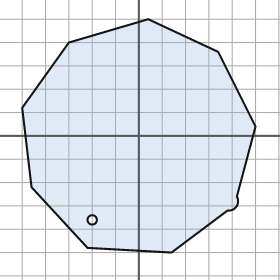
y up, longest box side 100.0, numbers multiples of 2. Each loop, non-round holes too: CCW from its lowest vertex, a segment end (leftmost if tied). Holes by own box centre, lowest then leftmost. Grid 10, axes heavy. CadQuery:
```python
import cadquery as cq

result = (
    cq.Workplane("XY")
    .moveTo(14.0, -50.0)
    .lineTo(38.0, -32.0)
    .threePointArc((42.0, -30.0), (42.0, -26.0))
    .lineTo(50.0, 4.0)
    .lineTo(34.0, 36.0)
    .lineTo(4.0, 50.0)
    .lineTo(-30.0, 40.0)
    .lineTo(-50.0, 12.0)
    .lineTo(-46.0, -22.0)
    .lineTo(-22.0, -48.0)
    .close()
    .moveTo(-20.0, -36.0)
    .circle(2.0)
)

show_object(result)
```